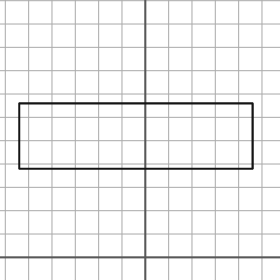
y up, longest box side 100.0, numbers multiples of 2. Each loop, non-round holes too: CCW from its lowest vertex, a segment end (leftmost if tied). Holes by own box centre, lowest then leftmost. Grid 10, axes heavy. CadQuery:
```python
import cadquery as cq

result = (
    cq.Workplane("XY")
    .moveTo(-54.0, 38.0)
    .lineTo(46.0, 38.0)
    .lineTo(46.0, 66.0)
    .lineTo(-54.0, 66.0)
    .close()
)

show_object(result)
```